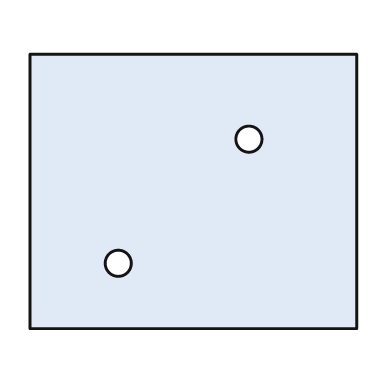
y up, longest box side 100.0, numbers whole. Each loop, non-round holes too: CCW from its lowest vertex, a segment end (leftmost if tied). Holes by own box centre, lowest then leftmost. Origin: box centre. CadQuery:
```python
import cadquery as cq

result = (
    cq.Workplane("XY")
    .moveTo(-50.0, -42.0)
    .lineTo(50.0, -42.0)
    .lineTo(50.0, 42.0)
    .lineTo(-50.0, 42.0)
    .close()
    .moveTo(-23.0, -22.0)
    .circle(4.0)
    .moveTo(17.0, 16.0)
    .circle(4.0)
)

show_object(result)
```